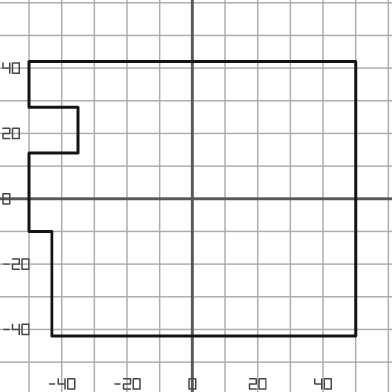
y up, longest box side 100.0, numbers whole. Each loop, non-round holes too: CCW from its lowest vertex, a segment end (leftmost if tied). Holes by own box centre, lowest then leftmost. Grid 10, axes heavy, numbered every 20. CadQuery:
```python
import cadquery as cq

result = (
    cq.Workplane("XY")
    .moveTo(-43.0, -42.0)
    .lineTo(50.0, -42.0)
    .lineTo(50.0, 42.0)
    .lineTo(-50.0, 42.0)
    .lineTo(-50.0, 28.0)
    .lineTo(-35.0, 28.0)
    .lineTo(-35.0, 14.0)
    .lineTo(-50.0, 14.0)
    .lineTo(-50.0, -10.0)
    .lineTo(-43.0, -10.0)
    .close()
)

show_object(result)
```